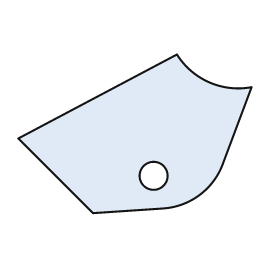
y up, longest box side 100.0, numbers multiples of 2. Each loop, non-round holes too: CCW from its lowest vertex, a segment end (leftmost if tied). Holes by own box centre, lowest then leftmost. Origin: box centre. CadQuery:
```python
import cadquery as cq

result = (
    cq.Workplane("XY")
    .moveTo(-18.0, -34.0)
    .lineTo(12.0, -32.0)
    .threePointArc((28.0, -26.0), (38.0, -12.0))
    .lineTo(50.0, 20.0)
    .threePointArc((32.0, 22.0), (18.0, 34.0))
    .lineTo(-50.0, -2.0)
    .close()
    .moveTo(8.0, -18.0)
    .circle(6.0)
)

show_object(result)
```